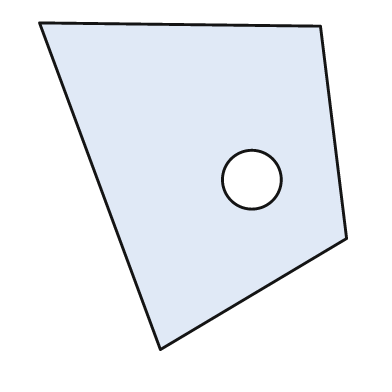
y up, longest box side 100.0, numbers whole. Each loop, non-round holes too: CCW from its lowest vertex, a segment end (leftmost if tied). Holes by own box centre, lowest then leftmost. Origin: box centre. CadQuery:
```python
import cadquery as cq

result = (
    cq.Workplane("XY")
    .moveTo(-10.0, -50.0)
    .lineTo(47.0, -16.0)
    .lineTo(39.0, 49.0)
    .lineTo(-47.0, 50.0)
    .close()
    .moveTo(18.0, 2.0)
    .circle(9.0)
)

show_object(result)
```